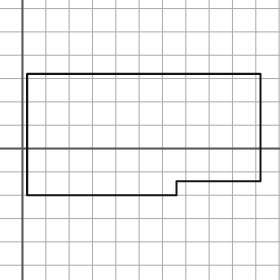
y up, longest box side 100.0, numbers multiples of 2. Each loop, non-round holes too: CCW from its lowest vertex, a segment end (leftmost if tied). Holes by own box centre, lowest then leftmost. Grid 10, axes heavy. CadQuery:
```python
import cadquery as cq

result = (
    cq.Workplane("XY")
    .moveTo(2.0, -20.0)
    .lineTo(66.0, -20.0)
    .lineTo(66.0, -14.0)
    .lineTo(102.0, -14.0)
    .lineTo(102.0, 32.0)
    .lineTo(2.0, 32.0)
    .close()
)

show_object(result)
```